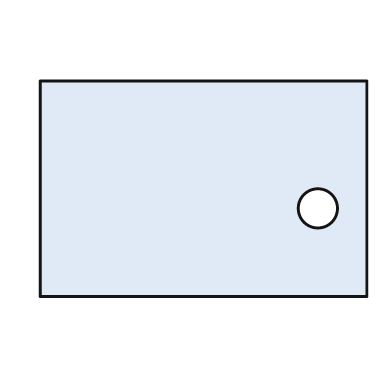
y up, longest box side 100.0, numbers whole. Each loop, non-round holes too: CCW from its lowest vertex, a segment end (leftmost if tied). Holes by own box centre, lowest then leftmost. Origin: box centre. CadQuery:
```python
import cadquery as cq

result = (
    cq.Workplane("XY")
    .moveTo(-50.0, -33.0)
    .lineTo(50.0, -33.0)
    .lineTo(50.0, 33.0)
    .lineTo(-50.0, 33.0)
    .close()
    .moveTo(35.0, -6.0)
    .circle(6.0)
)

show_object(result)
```